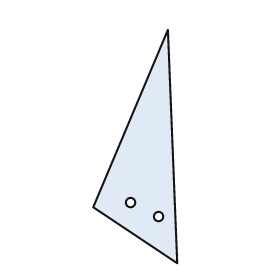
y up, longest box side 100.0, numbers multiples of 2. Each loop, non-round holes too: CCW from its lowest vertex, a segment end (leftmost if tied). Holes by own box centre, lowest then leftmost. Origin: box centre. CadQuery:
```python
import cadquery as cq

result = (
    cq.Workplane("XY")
    .moveTo(18.0, -50.0)
    .lineTo(14.0, 50.0)
    .lineTo(-18.0, -26.0)
    .close()
    .moveTo(10.0, -30.0)
    .circle(2.0)
    .moveTo(-2.0, -24.0)
    .circle(2.0)
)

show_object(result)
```